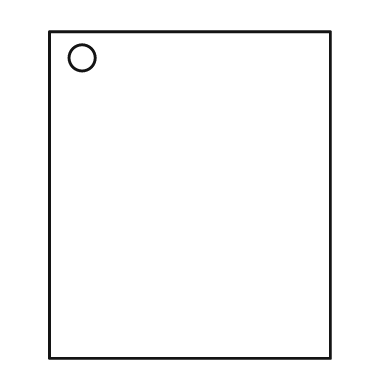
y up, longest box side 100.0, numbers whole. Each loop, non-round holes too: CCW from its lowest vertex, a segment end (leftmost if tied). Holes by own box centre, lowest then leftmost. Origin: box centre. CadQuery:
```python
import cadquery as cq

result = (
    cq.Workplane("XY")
    .moveTo(-43.0, -50.0)
    .lineTo(43.0, -50.0)
    .lineTo(43.0, 50.0)
    .lineTo(-43.0, 50.0)
    .close()
    .moveTo(-33.0, 42.0)
    .circle(4.0)
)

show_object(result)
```